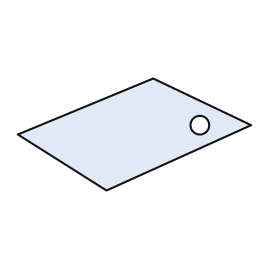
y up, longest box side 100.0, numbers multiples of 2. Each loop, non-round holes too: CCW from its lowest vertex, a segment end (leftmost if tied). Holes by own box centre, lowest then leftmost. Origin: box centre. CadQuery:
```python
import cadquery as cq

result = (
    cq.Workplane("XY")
    .moveTo(-12.0, -24.0)
    .lineTo(50.0, 4.0)
    .lineTo(8.0, 24.0)
    .lineTo(-50.0, 0.0)
    .close()
    .moveTo(28.0, 4.0)
    .circle(4.0)
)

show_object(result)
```